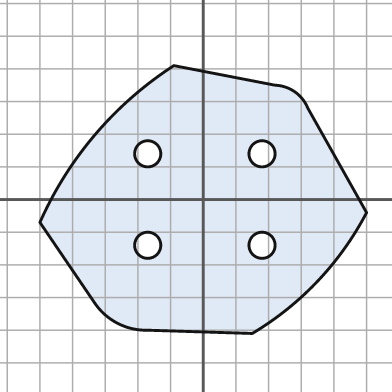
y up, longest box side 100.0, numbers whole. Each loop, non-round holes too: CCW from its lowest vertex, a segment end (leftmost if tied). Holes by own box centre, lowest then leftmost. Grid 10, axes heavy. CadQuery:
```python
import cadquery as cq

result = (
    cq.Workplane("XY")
    .moveTo(15.0, -41.0)
    .threePointArc((35.0, -25.0), (50.0, -4.0))
    .lineTo(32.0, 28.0)
    .threePointArc((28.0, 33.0), (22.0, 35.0))
    .lineTo(-9.0, 41.0)
    .threePointArc((-33.0, 20.0), (-50.0, -7.0))
    .lineTo(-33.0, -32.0)
    .threePointArc((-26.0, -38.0), (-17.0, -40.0))
    .close()
    .moveTo(-17.0, -14.0)
    .circle(4.0)
    .moveTo(18.0, -14.0)
    .circle(4.0)
    .moveTo(-17.0, 14.0)
    .circle(4.0)
    .moveTo(18.0, 14.0)
    .circle(4.0)
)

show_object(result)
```